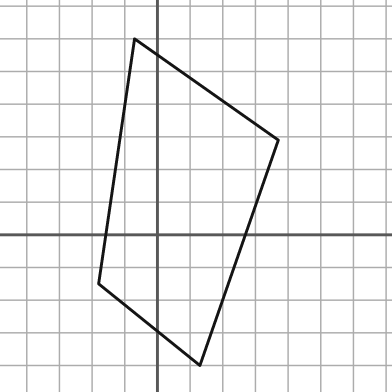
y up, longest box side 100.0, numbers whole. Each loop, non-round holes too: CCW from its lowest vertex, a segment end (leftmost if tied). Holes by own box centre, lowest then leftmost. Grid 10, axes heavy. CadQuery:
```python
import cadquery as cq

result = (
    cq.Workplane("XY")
    .moveTo(13.0, -40.0)
    .lineTo(37.0, 29.0)
    .lineTo(-7.0, 60.0)
    .lineTo(-18.0, -15.0)
    .close()
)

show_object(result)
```